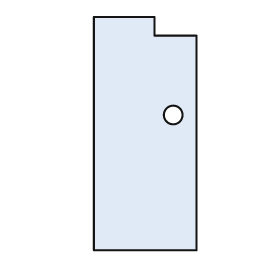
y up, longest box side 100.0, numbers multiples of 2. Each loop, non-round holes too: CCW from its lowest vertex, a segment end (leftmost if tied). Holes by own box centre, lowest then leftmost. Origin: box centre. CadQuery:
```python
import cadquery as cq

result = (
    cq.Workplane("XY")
    .moveTo(-22.0, -50.0)
    .lineTo(22.0, -50.0)
    .lineTo(22.0, 42.0)
    .lineTo(4.0, 42.0)
    .lineTo(4.0, 50.0)
    .lineTo(-22.0, 50.0)
    .close()
    .moveTo(12.0, 8.0)
    .circle(4.0)
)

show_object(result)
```